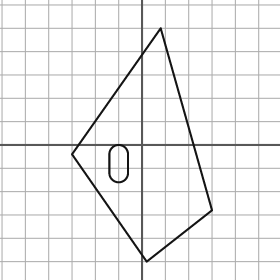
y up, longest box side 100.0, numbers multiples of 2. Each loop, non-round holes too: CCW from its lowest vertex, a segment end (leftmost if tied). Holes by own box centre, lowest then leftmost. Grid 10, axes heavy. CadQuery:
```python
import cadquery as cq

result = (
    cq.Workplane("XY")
    .moveTo(2.0, -50.0)
    .lineTo(30.0, -28.0)
    .lineTo(8.0, 50.0)
    .lineTo(-30.0, -4.0)
    .close()
    .moveTo(-14.0, -12.0)
    .threePointArc((-10.0, -16.0), (-6.0, -12.0))
    .lineTo(-6.0, -4.0)
    .threePointArc((-10.0, 0.0), (-14.0, -4.0))
    .close()
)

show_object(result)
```